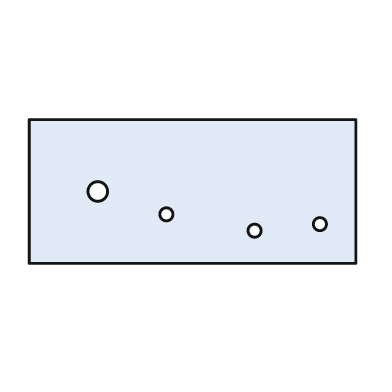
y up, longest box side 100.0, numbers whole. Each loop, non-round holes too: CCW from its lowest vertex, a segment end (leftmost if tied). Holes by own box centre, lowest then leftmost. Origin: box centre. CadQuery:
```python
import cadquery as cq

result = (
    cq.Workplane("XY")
    .moveTo(-50.0, -22.0)
    .lineTo(50.0, -22.0)
    .lineTo(50.0, 22.0)
    .lineTo(-50.0, 22.0)
    .close()
    .moveTo(19.0, -12.0)
    .circle(2.0)
    .moveTo(39.0, -10.0)
    .circle(2.0)
    .moveTo(-8.0, -7.0)
    .circle(2.0)
    .moveTo(-29.0, 0.0)
    .circle(3.0)
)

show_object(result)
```